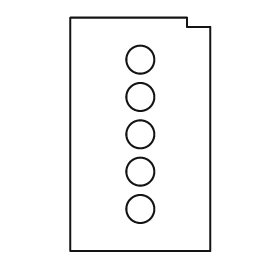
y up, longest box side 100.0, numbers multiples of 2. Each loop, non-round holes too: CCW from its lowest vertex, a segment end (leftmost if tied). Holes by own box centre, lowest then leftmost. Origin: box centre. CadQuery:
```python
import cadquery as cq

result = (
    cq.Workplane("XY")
    .moveTo(-30.0, -50.0)
    .lineTo(30.0, -50.0)
    .lineTo(30.0, 46.0)
    .lineTo(20.0, 46.0)
    .lineTo(20.0, 50.0)
    .lineTo(-30.0, 50.0)
    .close()
    .moveTo(0.0, -32.0)
    .circle(6.0)
    .moveTo(0.0, -16.0)
    .circle(6.0)
    .moveTo(0.0, 0.0)
    .circle(6.0)
    .moveTo(0.0, 16.0)
    .circle(6.0)
    .moveTo(0.0, 32.0)
    .circle(6.0)
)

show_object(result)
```